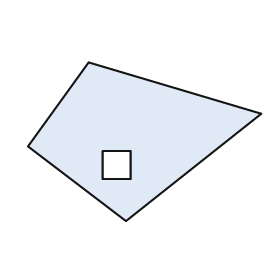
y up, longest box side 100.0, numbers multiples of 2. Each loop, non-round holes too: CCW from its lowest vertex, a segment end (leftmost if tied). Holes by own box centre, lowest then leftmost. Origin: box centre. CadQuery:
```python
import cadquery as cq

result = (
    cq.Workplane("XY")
    .moveTo(-8.0, -34.0)
    .lineTo(50.0, 12.0)
    .lineTo(-24.0, 34.0)
    .lineTo(-50.0, -2.0)
    .close()
    .moveTo(-18.0, -16.0)
    .lineTo(-6.0, -16.0)
    .lineTo(-6.0, -4.0)
    .lineTo(-18.0, -4.0)
    .close()
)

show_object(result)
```